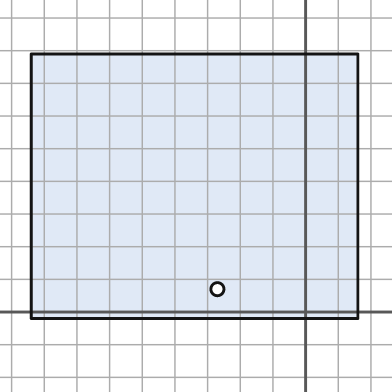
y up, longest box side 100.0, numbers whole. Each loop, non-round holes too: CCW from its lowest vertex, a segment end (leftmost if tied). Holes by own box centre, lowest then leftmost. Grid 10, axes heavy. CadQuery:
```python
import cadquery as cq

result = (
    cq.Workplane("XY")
    .moveTo(-84.0, -2.0)
    .lineTo(16.0, -2.0)
    .lineTo(16.0, 79.0)
    .lineTo(-84.0, 79.0)
    .close()
    .moveTo(-27.0, 7.0)
    .circle(2.0)
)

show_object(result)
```